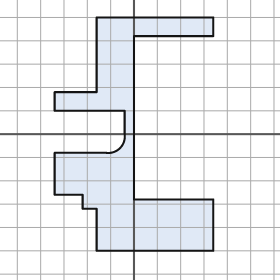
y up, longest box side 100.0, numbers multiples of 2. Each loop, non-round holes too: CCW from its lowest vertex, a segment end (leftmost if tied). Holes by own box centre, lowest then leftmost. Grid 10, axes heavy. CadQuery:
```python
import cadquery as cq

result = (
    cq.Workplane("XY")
    .moveTo(-16.0, -50.0)
    .lineTo(34.0, -50.0)
    .lineTo(34.0, -28.0)
    .lineTo(0.0, -28.0)
    .lineTo(0.0, 42.0)
    .lineTo(34.0, 42.0)
    .lineTo(34.0, 50.0)
    .lineTo(-16.0, 50.0)
    .lineTo(-16.0, 18.0)
    .lineTo(-34.0, 18.0)
    .lineTo(-34.0, 10.0)
    .lineTo(-4.0, 10.0)
    .lineTo(-4.0, 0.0)
    .threePointArc((-6.0, -6.0), (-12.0, -8.0))
    .lineTo(-34.0, -8.0)
    .lineTo(-34.0, -26.0)
    .lineTo(-22.0, -26.0)
    .lineTo(-22.0, -32.0)
    .lineTo(-16.0, -32.0)
    .close()
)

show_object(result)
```